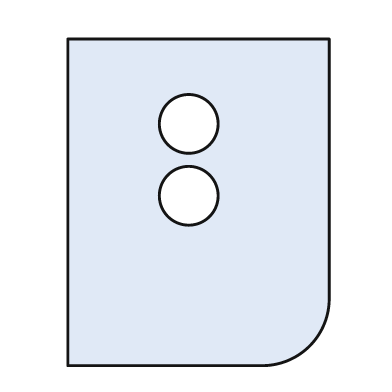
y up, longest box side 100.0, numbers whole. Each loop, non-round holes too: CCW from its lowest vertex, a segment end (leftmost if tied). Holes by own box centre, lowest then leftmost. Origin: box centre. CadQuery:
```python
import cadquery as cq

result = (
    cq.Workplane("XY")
    .moveTo(-40.0, -50.0)
    .lineTo(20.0, -50.0)
    .threePointArc((34.0, -44.0), (40.0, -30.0))
    .lineTo(40.0, 50.0)
    .lineTo(-40.0, 50.0)
    .close()
    .moveTo(-3.0, 2.0)
    .circle(9.0)
    .moveTo(-3.0, 24.0)
    .circle(9.0)
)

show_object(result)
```